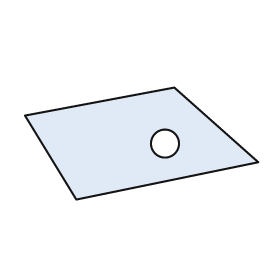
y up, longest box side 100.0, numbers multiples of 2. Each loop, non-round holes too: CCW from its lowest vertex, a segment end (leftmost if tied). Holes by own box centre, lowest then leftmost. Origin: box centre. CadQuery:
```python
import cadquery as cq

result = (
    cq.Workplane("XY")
    .moveTo(-28.0, -24.0)
    .lineTo(50.0, -8.0)
    .lineTo(14.0, 24.0)
    .lineTo(-50.0, 12.0)
    .close()
    .moveTo(10.0, 0.0)
    .circle(6.0)
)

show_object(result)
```